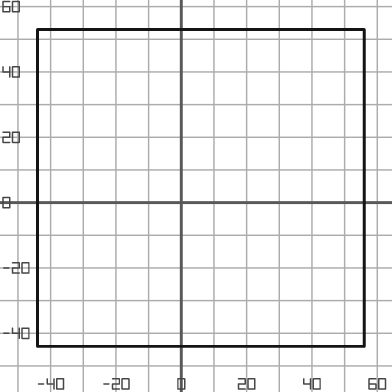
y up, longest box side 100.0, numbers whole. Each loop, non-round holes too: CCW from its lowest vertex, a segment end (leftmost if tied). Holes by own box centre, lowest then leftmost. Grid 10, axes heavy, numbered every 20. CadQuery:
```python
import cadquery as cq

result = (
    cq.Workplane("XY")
    .moveTo(-44.0, -44.0)
    .lineTo(56.0, -44.0)
    .lineTo(56.0, 53.0)
    .lineTo(-44.0, 53.0)
    .close()
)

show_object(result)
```